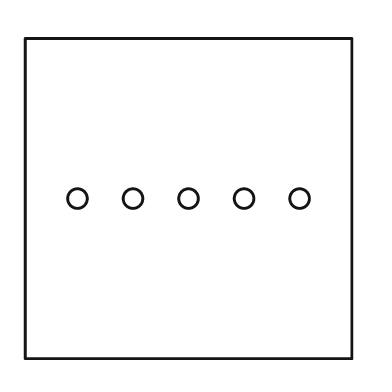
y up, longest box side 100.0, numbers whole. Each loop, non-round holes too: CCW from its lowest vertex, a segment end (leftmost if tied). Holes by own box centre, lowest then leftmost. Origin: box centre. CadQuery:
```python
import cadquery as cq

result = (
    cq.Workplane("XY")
    .moveTo(-50.0, -49.0)
    .lineTo(50.0, -49.0)
    .lineTo(50.0, 49.0)
    .lineTo(-50.0, 49.0)
    .close()
    .moveTo(-34.0, 0.0)
    .circle(3.0)
    .moveTo(-17.0, 0.0)
    .circle(3.0)
    .moveTo(0.0, 0.0)
    .circle(3.0)
    .moveTo(17.0, 0.0)
    .circle(3.0)
    .moveTo(34.0, 0.0)
    .circle(3.0)
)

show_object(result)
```